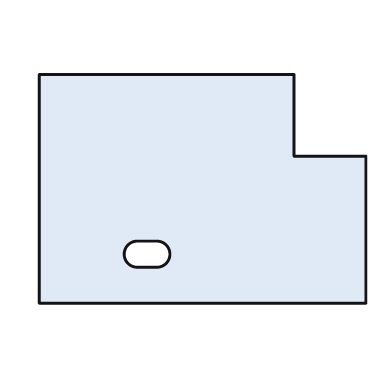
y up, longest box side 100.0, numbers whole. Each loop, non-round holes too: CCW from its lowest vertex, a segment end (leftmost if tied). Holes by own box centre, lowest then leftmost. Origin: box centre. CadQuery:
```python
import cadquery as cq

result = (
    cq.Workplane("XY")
    .moveTo(-50.0, -35.0)
    .lineTo(50.0, -35.0)
    .lineTo(50.0, 10.0)
    .lineTo(28.0, 10.0)
    .lineTo(28.0, 35.0)
    .lineTo(-50.0, 35.0)
    .close()
    .moveTo(-20.0, -24.0)
    .lineTo(-14.0, -24.0)
    .threePointArc((-10.0, -20.0), (-14.0, -16.0))
    .lineTo(-20.0, -16.0)
    .threePointArc((-24.0, -20.0), (-20.0, -24.0))
    .close()
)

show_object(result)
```